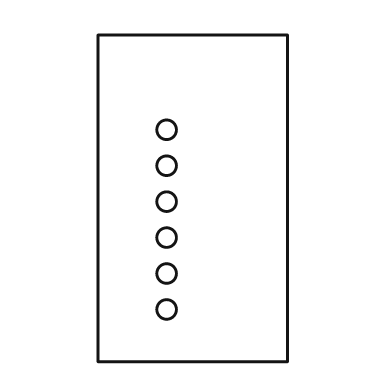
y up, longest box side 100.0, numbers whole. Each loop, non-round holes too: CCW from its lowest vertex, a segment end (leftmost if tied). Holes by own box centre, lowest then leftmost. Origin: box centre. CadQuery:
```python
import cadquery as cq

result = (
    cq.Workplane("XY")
    .moveTo(-29.0, -50.0)
    .lineTo(29.0, -50.0)
    .lineTo(29.0, 50.0)
    .lineTo(-29.0, 50.0)
    .close()
    .moveTo(-8.0, -34.0)
    .circle(3.0)
    .moveTo(-8.0, -23.0)
    .circle(3.0)
    .moveTo(-8.0, -12.0)
    .circle(3.0)
    .moveTo(-8.0, -1.0)
    .circle(3.0)
    .moveTo(-8.0, 10.0)
    .circle(3.0)
    .moveTo(-8.0, 21.0)
    .circle(3.0)
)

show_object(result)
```